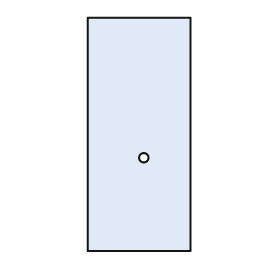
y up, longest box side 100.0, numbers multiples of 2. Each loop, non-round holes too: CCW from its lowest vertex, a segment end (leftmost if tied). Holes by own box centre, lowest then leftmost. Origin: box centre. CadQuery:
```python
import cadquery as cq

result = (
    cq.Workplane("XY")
    .moveTo(-22.0, -50.0)
    .lineTo(22.0, -50.0)
    .lineTo(22.0, 50.0)
    .lineTo(-22.0, 50.0)
    .close()
    .moveTo(2.0, -10.0)
    .circle(2.0)
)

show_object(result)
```